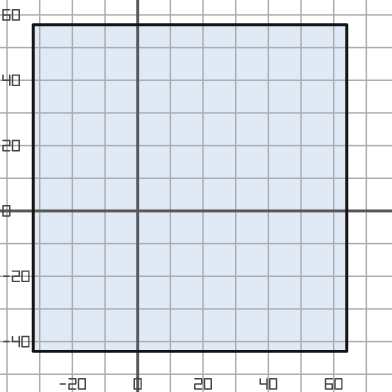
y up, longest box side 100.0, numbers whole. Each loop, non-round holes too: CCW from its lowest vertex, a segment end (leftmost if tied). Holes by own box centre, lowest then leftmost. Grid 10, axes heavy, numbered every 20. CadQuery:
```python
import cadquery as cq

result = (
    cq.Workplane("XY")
    .moveTo(-32.0, -43.0)
    .lineTo(64.0, -43.0)
    .lineTo(64.0, 57.0)
    .lineTo(-32.0, 57.0)
    .close()
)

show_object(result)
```